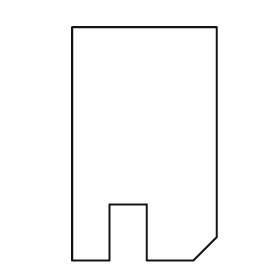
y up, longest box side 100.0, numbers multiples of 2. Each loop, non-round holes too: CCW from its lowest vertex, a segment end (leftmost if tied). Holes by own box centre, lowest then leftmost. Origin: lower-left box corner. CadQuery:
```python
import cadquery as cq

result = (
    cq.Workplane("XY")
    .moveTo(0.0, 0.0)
    .lineTo(16.0, 0.0)
    .lineTo(16.0, 24.0)
    .lineTo(32.0, 24.0)
    .lineTo(32.0, 0.0)
    .lineTo(52.0, 0.0)
    .lineTo(62.0, 10.0)
    .lineTo(62.0, 100.0)
    .lineTo(0.0, 100.0)
    .close()
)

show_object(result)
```